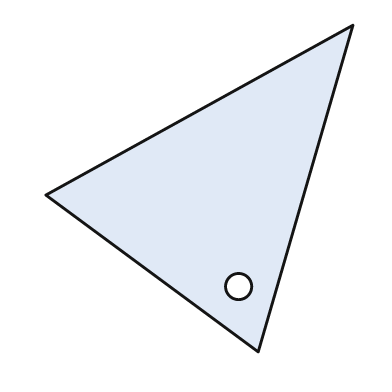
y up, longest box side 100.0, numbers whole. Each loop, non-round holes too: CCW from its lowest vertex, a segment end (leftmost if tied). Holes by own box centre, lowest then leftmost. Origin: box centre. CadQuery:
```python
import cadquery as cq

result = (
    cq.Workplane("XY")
    .moveTo(18.0, -50.0)
    .lineTo(47.0, 50.0)
    .lineTo(-47.0, -2.0)
    .close()
    .moveTo(12.0, -30.0)
    .circle(4.0)
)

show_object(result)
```